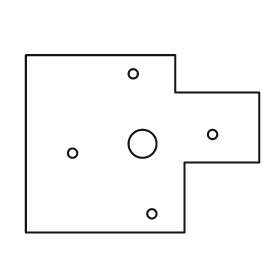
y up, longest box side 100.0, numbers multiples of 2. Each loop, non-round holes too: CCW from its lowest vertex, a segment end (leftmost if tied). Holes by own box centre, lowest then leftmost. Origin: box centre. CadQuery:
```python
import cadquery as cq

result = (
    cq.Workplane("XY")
    .moveTo(-50.0, -38.0)
    .lineTo(18.0, -38.0)
    .lineTo(18.0, -8.0)
    .lineTo(50.0, -8.0)
    .lineTo(50.0, 22.0)
    .lineTo(14.0, 22.0)
    .lineTo(14.0, 38.0)
    .lineTo(-50.0, 38.0)
    .close()
    .moveTo(4.0, -30.0)
    .circle(2.0)
    .moveTo(-30.0, -4.0)
    .circle(2.0)
    .moveTo(0.0, 0.0)
    .circle(6.0)
    .moveTo(30.0, 4.0)
    .circle(2.0)
    .moveTo(-4.0, 30.0)
    .circle(2.0)
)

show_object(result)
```